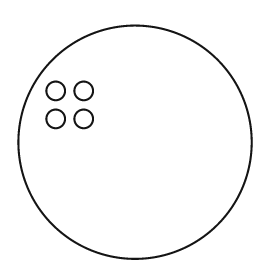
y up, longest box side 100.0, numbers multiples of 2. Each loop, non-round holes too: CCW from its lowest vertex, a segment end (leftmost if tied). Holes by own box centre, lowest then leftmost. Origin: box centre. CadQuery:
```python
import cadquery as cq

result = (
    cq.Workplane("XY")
    .moveTo(0.0, 0.0)
    .circle(50.0)
    .moveTo(-34.0, 10.0)
    .circle(4.0)
    .moveTo(-22.0, 10.0)
    .circle(4.0)
    .moveTo(-34.0, 22.0)
    .circle(4.0)
    .moveTo(-22.0, 22.0)
    .circle(4.0)
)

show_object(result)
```